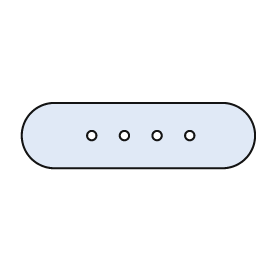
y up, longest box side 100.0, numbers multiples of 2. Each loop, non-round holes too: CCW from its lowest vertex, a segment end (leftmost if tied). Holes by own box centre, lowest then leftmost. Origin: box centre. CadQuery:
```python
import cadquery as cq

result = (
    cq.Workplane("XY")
    .moveTo(-36.0, -14.0)
    .lineTo(36.0, -14.0)
    .threePointArc((50.0, 0.0), (36.0, 14.0))
    .lineTo(-36.0, 14.0)
    .threePointArc((-50.0, 0.0), (-36.0, -14.0))
    .close()
    .moveTo(-20.0, 0.0)
    .circle(2.0)
    .moveTo(-6.0, 0.0)
    .circle(2.0)
    .moveTo(8.0, 0.0)
    .circle(2.0)
    .moveTo(22.0, 0.0)
    .circle(2.0)
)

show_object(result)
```